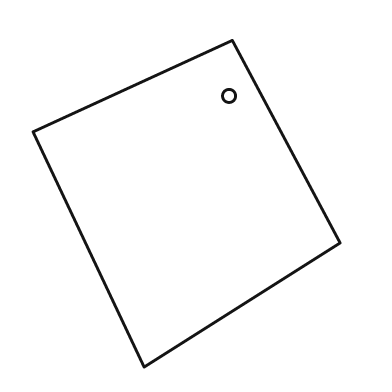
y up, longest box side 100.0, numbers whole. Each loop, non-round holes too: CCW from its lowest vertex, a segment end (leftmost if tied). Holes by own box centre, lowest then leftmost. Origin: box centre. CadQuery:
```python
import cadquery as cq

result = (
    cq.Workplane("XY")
    .moveTo(-13.0, -50.0)
    .lineTo(47.0, -12.0)
    .lineTo(14.0, 50.0)
    .lineTo(-47.0, 22.0)
    .close()
    .moveTo(13.0, 33.0)
    .circle(2.0)
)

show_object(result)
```